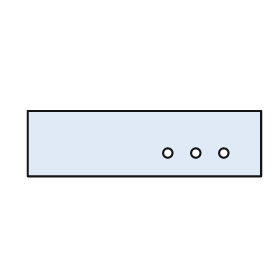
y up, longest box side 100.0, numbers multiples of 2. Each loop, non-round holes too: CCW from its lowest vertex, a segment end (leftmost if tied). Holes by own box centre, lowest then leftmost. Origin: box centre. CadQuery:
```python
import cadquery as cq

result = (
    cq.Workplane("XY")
    .moveTo(-50.0, -14.0)
    .lineTo(50.0, -14.0)
    .lineTo(50.0, 14.0)
    .lineTo(-50.0, 14.0)
    .close()
    .moveTo(10.0, -4.0)
    .circle(2.0)
    .moveTo(22.0, -4.0)
    .circle(2.0)
    .moveTo(34.0, -4.0)
    .circle(2.0)
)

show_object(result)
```